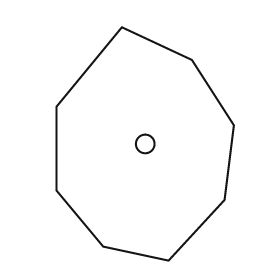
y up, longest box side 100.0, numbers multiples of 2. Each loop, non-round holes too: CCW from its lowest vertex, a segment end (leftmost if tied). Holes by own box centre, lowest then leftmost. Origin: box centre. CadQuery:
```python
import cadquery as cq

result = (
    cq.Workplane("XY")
    .moveTo(10.0, -50.0)
    .lineTo(34.0, -24.0)
    .lineTo(38.0, 8.0)
    .lineTo(20.0, 36.0)
    .lineTo(-10.0, 50.0)
    .lineTo(-38.0, 16.0)
    .lineTo(-38.0, -20.0)
    .lineTo(-18.0, -44.0)
    .close()
    .moveTo(0.0, 0.0)
    .circle(4.0)
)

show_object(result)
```